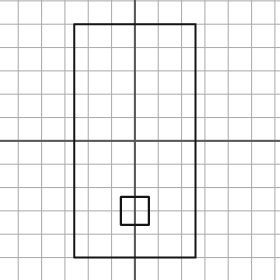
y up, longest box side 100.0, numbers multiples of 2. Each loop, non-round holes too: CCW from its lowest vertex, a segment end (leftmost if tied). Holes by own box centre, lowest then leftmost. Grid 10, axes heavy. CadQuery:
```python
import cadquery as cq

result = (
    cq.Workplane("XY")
    .moveTo(-26.0, -50.0)
    .lineTo(26.0, -50.0)
    .lineTo(26.0, 50.0)
    .lineTo(-26.0, 50.0)
    .close()
    .moveTo(-6.0, -36.0)
    .lineTo(6.0, -36.0)
    .lineTo(6.0, -24.0)
    .lineTo(-6.0, -24.0)
    .close()
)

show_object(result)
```